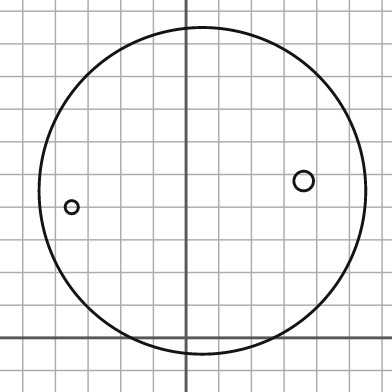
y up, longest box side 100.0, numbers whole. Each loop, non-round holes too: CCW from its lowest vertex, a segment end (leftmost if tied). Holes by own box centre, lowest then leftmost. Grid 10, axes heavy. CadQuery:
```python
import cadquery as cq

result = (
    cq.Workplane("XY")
    .moveTo(5.0, 45.0)
    .circle(50.0)
    .moveTo(-35.0, 40.0)
    .circle(2.0)
    .moveTo(36.0, 48.0)
    .circle(3.0)
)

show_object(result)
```